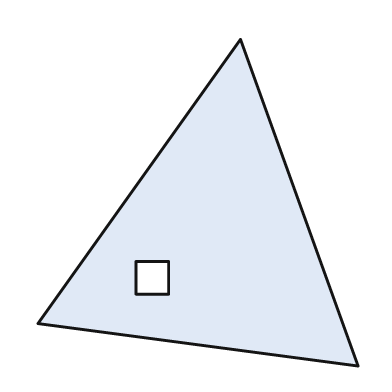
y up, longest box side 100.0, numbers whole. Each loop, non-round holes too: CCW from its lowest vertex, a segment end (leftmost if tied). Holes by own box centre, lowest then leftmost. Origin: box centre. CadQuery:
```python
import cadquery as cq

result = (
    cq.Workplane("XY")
    .moveTo(49.0, -50.0)
    .lineTo(13.0, 50.0)
    .lineTo(-49.0, -37.0)
    .close()
    .moveTo(-19.0, -28.0)
    .lineTo(-9.0, -28.0)
    .lineTo(-9.0, -18.0)
    .lineTo(-19.0, -18.0)
    .close()
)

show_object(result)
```